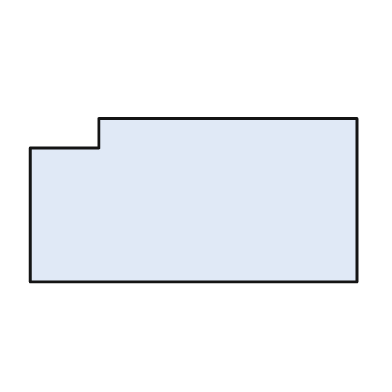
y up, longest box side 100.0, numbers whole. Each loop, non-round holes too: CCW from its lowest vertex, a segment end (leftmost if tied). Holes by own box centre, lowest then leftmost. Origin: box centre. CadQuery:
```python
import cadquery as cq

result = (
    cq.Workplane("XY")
    .moveTo(-50.0, -25.0)
    .lineTo(50.0, -25.0)
    .lineTo(50.0, 25.0)
    .lineTo(-29.0, 25.0)
    .lineTo(-29.0, 16.0)
    .lineTo(-50.0, 16.0)
    .close()
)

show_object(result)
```